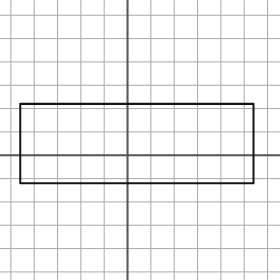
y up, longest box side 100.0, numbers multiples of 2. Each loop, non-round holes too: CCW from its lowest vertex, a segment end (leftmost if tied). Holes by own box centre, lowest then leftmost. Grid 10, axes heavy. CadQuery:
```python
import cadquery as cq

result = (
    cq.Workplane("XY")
    .moveTo(-46.0, -12.0)
    .lineTo(54.0, -12.0)
    .lineTo(54.0, 22.0)
    .lineTo(-46.0, 22.0)
    .close()
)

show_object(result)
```